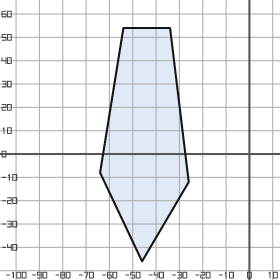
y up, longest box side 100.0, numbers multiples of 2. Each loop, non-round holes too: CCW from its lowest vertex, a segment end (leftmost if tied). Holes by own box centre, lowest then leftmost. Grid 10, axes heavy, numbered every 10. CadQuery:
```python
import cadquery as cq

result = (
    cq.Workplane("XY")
    .moveTo(-46.0, -46.0)
    .lineTo(-26.0, -12.0)
    .lineTo(-34.0, 54.0)
    .lineTo(-54.0, 54.0)
    .lineTo(-64.0, -8.0)
    .close()
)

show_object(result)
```